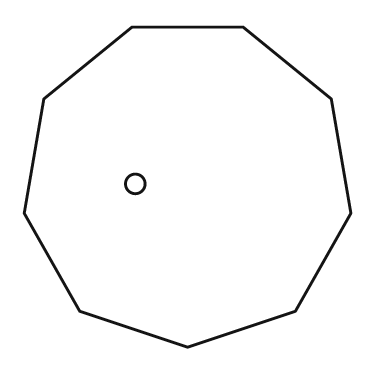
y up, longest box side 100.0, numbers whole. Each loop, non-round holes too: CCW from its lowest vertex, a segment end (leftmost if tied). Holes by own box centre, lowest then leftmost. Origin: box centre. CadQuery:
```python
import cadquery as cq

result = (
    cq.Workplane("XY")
    .moveTo(0.0, -49.0)
    .lineTo(33.0, -38.0)
    .lineTo(50.0, -8.0)
    .lineTo(44.0, 27.0)
    .lineTo(17.0, 49.0)
    .lineTo(-17.0, 49.0)
    .lineTo(-44.0, 27.0)
    .lineTo(-50.0, -8.0)
    .lineTo(-33.0, -38.0)
    .close()
    .moveTo(-16.0, 1.0)
    .circle(3.0)
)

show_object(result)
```